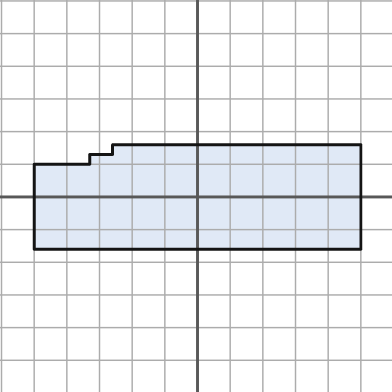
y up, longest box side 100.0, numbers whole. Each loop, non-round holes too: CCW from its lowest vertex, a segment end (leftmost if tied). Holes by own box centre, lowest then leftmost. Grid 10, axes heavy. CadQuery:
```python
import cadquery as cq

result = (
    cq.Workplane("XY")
    .moveTo(-50.0, -16.0)
    .lineTo(50.0, -16.0)
    .lineTo(50.0, 16.0)
    .lineTo(-26.0, 16.0)
    .lineTo(-26.0, 13.0)
    .lineTo(-33.0, 13.0)
    .lineTo(-33.0, 10.0)
    .lineTo(-50.0, 10.0)
    .close()
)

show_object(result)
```